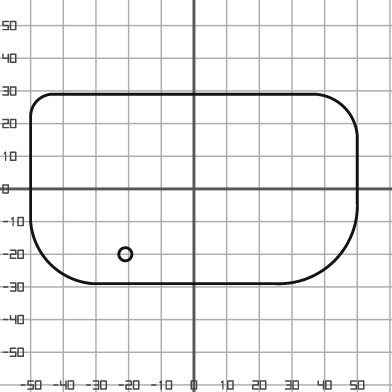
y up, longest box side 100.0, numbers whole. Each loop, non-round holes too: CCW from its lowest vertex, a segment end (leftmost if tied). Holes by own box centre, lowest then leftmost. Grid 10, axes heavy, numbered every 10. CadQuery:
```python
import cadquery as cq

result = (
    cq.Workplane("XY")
    .moveTo(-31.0, -29.0)
    .lineTo(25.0, -29.0)
    .threePointArc((43.0, -22.0), (50.0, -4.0))
    .lineTo(50.0, 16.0)
    .threePointArc((46.0, 25.0), (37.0, 29.0))
    .lineTo(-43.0, 29.0)
    .threePointArc((-48.0, 27.0), (-50.0, 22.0))
    .lineTo(-50.0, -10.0)
    .threePointArc((-44.0, -23.0), (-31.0, -29.0))
    .close()
    .moveTo(-21.0, -20.0)
    .circle(2.0)
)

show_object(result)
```